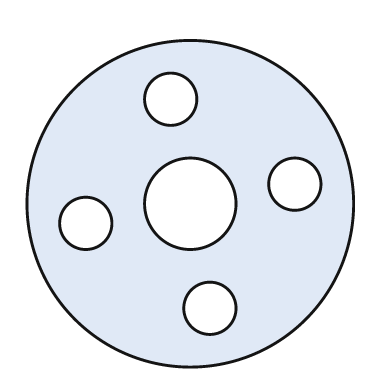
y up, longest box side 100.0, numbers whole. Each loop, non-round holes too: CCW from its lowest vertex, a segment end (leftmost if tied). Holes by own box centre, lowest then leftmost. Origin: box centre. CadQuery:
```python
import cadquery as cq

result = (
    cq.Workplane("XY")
    .moveTo(0.0, 0.0)
    .circle(50.0)
    .moveTo(6.0, -32.0)
    .circle(8.0)
    .moveTo(-32.0, -6.0)
    .circle(8.0)
    .moveTo(0.0, 0.0)
    .circle(14.0)
    .moveTo(32.0, 6.0)
    .circle(8.0)
    .moveTo(-6.0, 32.0)
    .circle(8.0)
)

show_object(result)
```